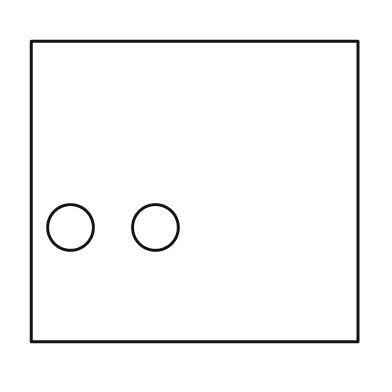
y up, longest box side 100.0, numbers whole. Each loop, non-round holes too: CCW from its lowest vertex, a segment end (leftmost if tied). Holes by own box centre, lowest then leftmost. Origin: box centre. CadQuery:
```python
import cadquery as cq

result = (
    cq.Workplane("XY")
    .moveTo(-50.0, -46.0)
    .lineTo(50.0, -46.0)
    .lineTo(50.0, 46.0)
    .lineTo(-50.0, 46.0)
    .close()
    .moveTo(-38.0, -11.0)
    .circle(7.0)
    .moveTo(-12.0, -11.0)
    .circle(7.0)
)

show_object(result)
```